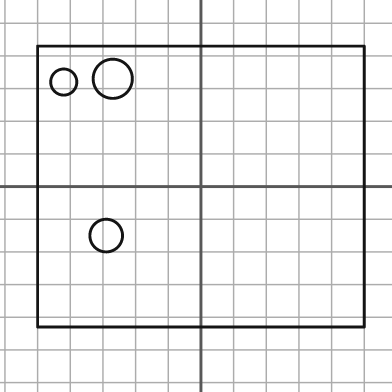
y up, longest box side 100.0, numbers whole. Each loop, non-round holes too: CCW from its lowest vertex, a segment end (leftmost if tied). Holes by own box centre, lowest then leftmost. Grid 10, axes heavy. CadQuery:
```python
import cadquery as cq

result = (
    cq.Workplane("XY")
    .moveTo(-50.0, -43.0)
    .lineTo(50.0, -43.0)
    .lineTo(50.0, 43.0)
    .lineTo(-50.0, 43.0)
    .close()
    .moveTo(-29.0, -15.0)
    .circle(5.0)
    .moveTo(-42.0, 32.0)
    .circle(4.0)
    .moveTo(-27.0, 33.0)
    .circle(6.0)
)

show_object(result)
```